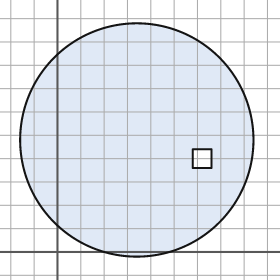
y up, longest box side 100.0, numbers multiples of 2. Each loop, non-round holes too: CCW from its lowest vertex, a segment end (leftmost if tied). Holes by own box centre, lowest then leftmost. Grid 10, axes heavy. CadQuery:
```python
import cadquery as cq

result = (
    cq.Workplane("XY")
    .moveTo(34.0, 48.0)
    .circle(50.0)
    .moveTo(58.0, 36.0)
    .lineTo(66.0, 36.0)
    .lineTo(66.0, 44.0)
    .lineTo(58.0, 44.0)
    .close()
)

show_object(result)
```